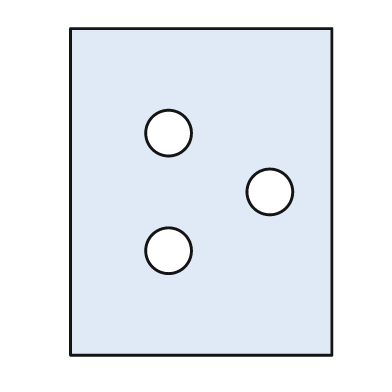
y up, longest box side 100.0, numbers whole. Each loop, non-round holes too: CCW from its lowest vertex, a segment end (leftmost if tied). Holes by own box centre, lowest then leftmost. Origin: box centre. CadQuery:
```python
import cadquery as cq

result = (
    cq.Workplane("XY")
    .moveTo(-40.0, -50.0)
    .lineTo(40.0, -50.0)
    .lineTo(40.0, 50.0)
    .lineTo(-40.0, 50.0)
    .close()
    .moveTo(-10.0, -18.0)
    .circle(7.0)
    .moveTo(21.0, 0.0)
    .circle(7.0)
    .moveTo(-10.0, 18.0)
    .circle(7.0)
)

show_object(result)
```